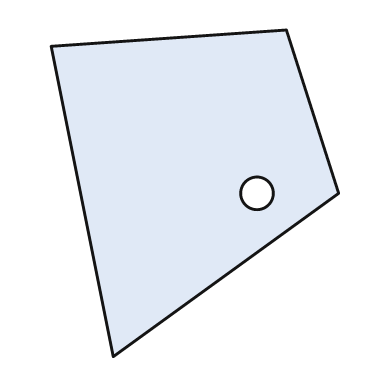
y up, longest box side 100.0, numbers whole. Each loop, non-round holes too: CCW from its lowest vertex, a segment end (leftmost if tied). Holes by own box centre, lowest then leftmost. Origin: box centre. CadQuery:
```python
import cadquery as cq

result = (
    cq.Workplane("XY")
    .moveTo(-25.0, -50.0)
    .lineTo(44.0, 0.0)
    .lineTo(28.0, 50.0)
    .lineTo(-44.0, 45.0)
    .close()
    .moveTo(19.0, 0.0)
    .circle(5.0)
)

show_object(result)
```